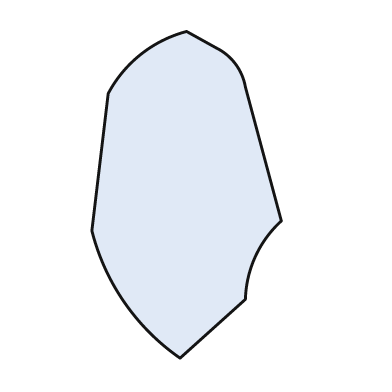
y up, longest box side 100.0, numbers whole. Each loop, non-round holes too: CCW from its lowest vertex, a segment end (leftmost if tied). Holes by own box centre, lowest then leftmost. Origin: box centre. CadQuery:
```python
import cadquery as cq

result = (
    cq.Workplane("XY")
    .moveTo(-2.0, -50.0)
    .lineTo(18.0, -32.0)
    .threePointArc((21.0, -19.0), (29.0, -8.0))
    .lineTo(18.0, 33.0)
    .threePointArc((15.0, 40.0), (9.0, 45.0))
    .lineTo(0.0, 50.0)
    .threePointArc((-14.0, 43.0), (-24.0, 31.0))
    .lineTo(-29.0, -11.0)
    .threePointArc((-19.0, -33.0), (-2.0, -50.0))
    .close()
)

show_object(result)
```